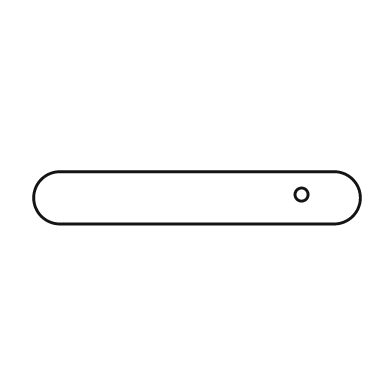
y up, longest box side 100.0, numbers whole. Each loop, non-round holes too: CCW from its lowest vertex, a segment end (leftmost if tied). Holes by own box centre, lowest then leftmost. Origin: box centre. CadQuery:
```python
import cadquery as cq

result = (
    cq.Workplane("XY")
    .moveTo(-42.0, -8.0)
    .lineTo(42.0, -8.0)
    .threePointArc((50.0, 0.0), (42.0, 8.0))
    .lineTo(-42.0, 8.0)
    .threePointArc((-50.0, 0.0), (-42.0, -8.0))
    .close()
    .moveTo(32.0, 1.0)
    .circle(2.0)
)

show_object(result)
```